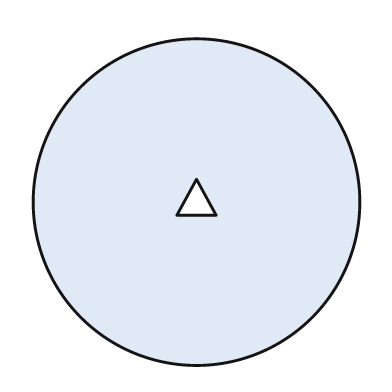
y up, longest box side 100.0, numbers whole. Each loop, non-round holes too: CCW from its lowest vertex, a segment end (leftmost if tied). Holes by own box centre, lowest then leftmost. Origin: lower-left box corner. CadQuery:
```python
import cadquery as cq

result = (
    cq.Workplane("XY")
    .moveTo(50.0, 50.0)
    .circle(50.0)
    .moveTo(44.0, 46.0)
    .lineTo(56.0, 46.0)
    .lineTo(50.0, 57.0)
    .close()
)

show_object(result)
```